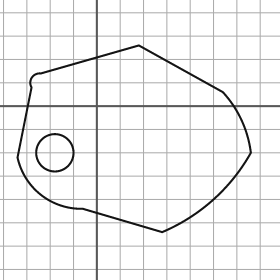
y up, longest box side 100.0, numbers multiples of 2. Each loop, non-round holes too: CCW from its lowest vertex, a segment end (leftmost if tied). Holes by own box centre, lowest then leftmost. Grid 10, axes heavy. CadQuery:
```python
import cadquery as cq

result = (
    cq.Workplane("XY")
    .moveTo(28.0, -54.0)
    .threePointArc((50.0, -40.0), (66.0, -20.0))
    .threePointArc((62.0, -6.0), (54.0, 6.0))
    .lineTo(18.0, 26.0)
    .lineTo(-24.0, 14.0)
    .threePointArc((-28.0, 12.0), (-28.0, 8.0))
    .lineTo(-34.0, -22.0)
    .threePointArc((-24.0, -38.0), (-6.0, -44.0))
    .close()
    .moveTo(-18.0, -20.0)
    .circle(8.0)
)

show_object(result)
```